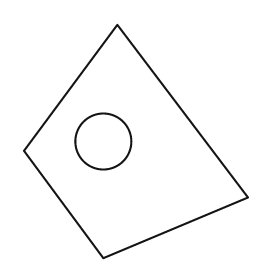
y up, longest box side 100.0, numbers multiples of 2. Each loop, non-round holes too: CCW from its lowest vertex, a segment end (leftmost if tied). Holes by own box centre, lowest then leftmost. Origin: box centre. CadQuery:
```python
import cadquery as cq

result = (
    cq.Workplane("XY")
    .moveTo(-14.0, -50.0)
    .lineTo(48.0, -24.0)
    .lineTo(-8.0, 50.0)
    .lineTo(-48.0, -4.0)
    .close()
    .moveTo(-14.0, 0.0)
    .circle(12.0)
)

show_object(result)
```